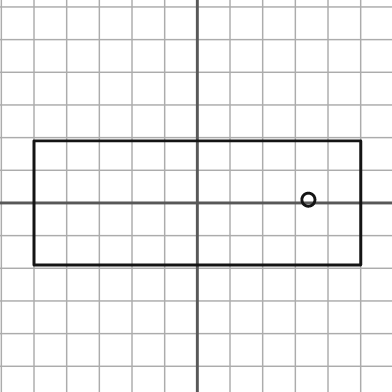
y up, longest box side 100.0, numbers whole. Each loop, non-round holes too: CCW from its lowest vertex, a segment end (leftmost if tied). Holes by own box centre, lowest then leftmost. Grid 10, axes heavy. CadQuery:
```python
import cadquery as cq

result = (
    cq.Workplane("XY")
    .moveTo(-50.0, -19.0)
    .lineTo(50.0, -19.0)
    .lineTo(50.0, 19.0)
    .lineTo(-50.0, 19.0)
    .close()
    .moveTo(34.0, 1.0)
    .circle(2.0)
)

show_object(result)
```